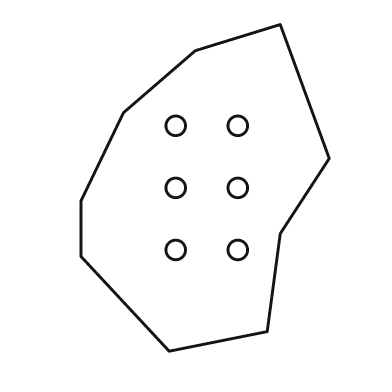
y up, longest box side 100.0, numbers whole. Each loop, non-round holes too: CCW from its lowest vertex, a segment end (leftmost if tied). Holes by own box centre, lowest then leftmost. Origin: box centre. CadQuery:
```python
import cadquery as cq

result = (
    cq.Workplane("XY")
    .moveTo(-11.0, -50.0)
    .lineTo(19.0, -44.0)
    .lineTo(23.0, -14.0)
    .lineTo(38.0, 9.0)
    .lineTo(23.0, 50.0)
    .lineTo(-3.0, 42.0)
    .lineTo(-25.0, 23.0)
    .lineTo(-38.0, -4.0)
    .lineTo(-38.0, -21.0)
    .close()
    .moveTo(-9.0, -19.0)
    .circle(3.0)
    .moveTo(10.0, -19.0)
    .circle(3.0)
    .moveTo(-9.0, 0.0)
    .circle(3.0)
    .moveTo(10.0, 0.0)
    .circle(3.0)
    .moveTo(-9.0, 19.0)
    .circle(3.0)
    .moveTo(10.0, 19.0)
    .circle(3.0)
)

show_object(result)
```